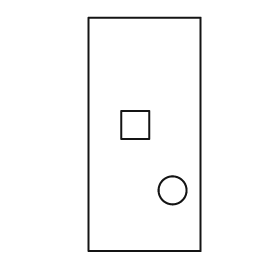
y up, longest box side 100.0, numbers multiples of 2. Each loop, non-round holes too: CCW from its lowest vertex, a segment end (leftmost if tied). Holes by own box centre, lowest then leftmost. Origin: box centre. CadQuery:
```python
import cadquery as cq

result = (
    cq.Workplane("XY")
    .moveTo(-24.0, -50.0)
    .lineTo(24.0, -50.0)
    .lineTo(24.0, 50.0)
    .lineTo(-24.0, 50.0)
    .close()
    .moveTo(12.0, -24.0)
    .circle(6.0)
    .moveTo(-10.0, -2.0)
    .lineTo(2.0, -2.0)
    .lineTo(2.0, 10.0)
    .lineTo(-10.0, 10.0)
    .close()
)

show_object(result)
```